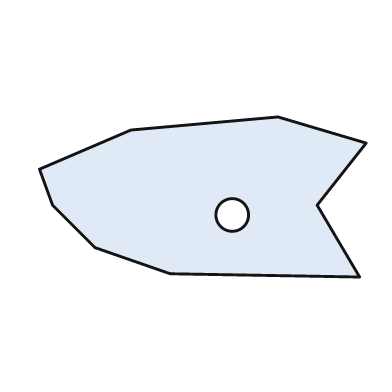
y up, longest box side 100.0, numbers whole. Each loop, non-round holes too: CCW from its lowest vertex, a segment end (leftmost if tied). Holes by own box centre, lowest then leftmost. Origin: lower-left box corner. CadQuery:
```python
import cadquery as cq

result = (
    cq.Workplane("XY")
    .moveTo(98.0, 0.0)
    .lineTo(85.0, 22.0)
    .lineTo(100.0, 41.0)
    .lineTo(73.0, 49.0)
    .lineTo(28.0, 45.0)
    .lineTo(0.0, 33.0)
    .lineTo(4.0, 22.0)
    .lineTo(17.0, 9.0)
    .lineTo(40.0, 1.0)
    .close()
    .moveTo(59.0, 19.0)
    .circle(5.0)
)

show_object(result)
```